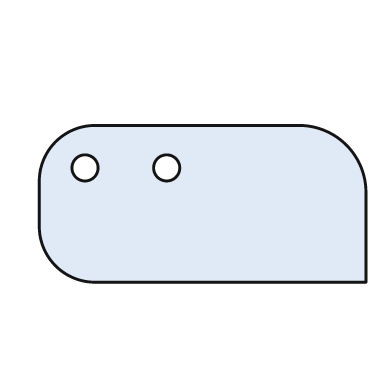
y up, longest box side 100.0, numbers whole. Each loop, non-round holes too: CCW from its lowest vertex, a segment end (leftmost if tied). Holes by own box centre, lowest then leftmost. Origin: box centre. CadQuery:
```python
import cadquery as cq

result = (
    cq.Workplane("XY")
    .moveTo(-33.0, -24.0)
    .lineTo(50.0, -24.0)
    .lineTo(50.0, 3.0)
    .threePointArc((44.0, 18.0), (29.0, 24.0))
    .lineTo(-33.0, 24.0)
    .threePointArc((-45.0, 19.0), (-50.0, 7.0))
    .lineTo(-50.0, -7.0)
    .threePointArc((-45.0, -19.0), (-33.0, -24.0))
    .close()
    .moveTo(-36.0, 11.0)
    .circle(4.0)
    .moveTo(-11.0, 11.0)
    .circle(4.0)
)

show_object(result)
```